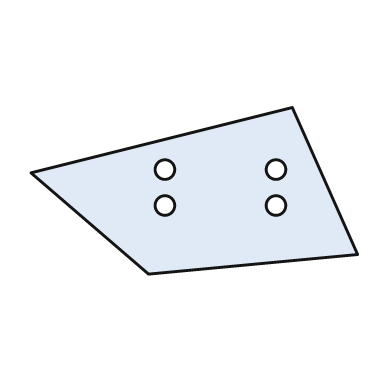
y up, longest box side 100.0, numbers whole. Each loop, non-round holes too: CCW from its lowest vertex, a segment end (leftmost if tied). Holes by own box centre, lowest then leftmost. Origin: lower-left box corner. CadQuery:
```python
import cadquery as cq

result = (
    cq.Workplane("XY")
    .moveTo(36.0, 0.0)
    .lineTo(100.0, 6.0)
    .lineTo(80.0, 51.0)
    .lineTo(0.0, 31.0)
    .close()
    .moveTo(41.0, 21.0)
    .circle(3.0)
    .moveTo(75.0, 21.0)
    .circle(3.0)
    .moveTo(41.0, 32.0)
    .circle(3.0)
    .moveTo(75.0, 32.0)
    .circle(3.0)
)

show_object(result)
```